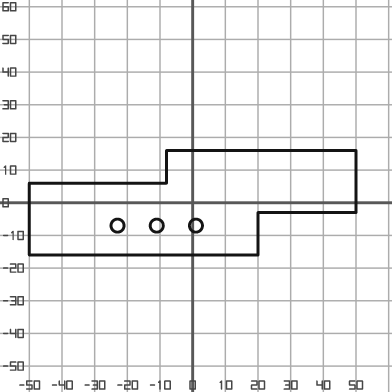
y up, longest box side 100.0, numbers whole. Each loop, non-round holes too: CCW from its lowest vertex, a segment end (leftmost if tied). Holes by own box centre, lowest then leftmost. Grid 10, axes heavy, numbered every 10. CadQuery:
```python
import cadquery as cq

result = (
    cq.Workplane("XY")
    .moveTo(-50.0, -16.0)
    .lineTo(20.0, -16.0)
    .lineTo(20.0, -3.0)
    .lineTo(50.0, -3.0)
    .lineTo(50.0, 16.0)
    .lineTo(-8.0, 16.0)
    .lineTo(-8.0, 6.0)
    .lineTo(-50.0, 6.0)
    .close()
    .moveTo(-23.0, -7.0)
    .circle(2.0)
    .moveTo(-11.0, -7.0)
    .circle(2.0)
    .moveTo(1.0, -7.0)
    .circle(2.0)
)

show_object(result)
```